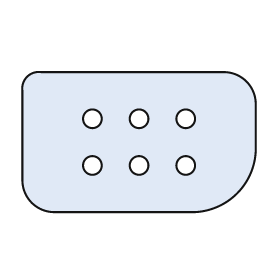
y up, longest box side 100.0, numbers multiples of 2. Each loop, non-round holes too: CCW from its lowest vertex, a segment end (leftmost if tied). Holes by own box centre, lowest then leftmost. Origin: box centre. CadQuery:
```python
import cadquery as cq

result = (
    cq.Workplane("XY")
    .moveTo(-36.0, -30.0)
    .lineTo(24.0, -30.0)
    .threePointArc((42.0, -22.0), (50.0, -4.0))
    .lineTo(50.0, 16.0)
    .threePointArc((46.0, 26.0), (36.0, 30.0))
    .lineTo(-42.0, 30.0)
    .threePointArc((-48.0, 28.0), (-50.0, 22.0))
    .lineTo(-50.0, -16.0)
    .threePointArc((-46.0, -26.0), (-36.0, -30.0))
    .close()
    .moveTo(-20.0, -10.0)
    .circle(4.0)
    .moveTo(0.0, -10.0)
    .circle(4.0)
    .moveTo(20.0, -10.0)
    .circle(4.0)
    .moveTo(-20.0, 10.0)
    .circle(4.0)
    .moveTo(0.0, 10.0)
    .circle(4.0)
    .moveTo(20.0, 10.0)
    .circle(4.0)
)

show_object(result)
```